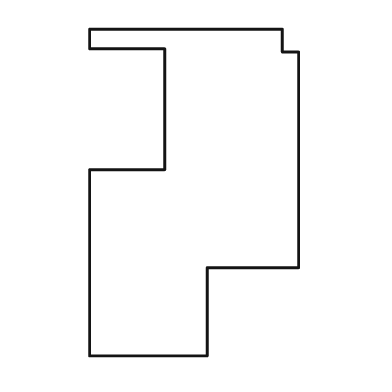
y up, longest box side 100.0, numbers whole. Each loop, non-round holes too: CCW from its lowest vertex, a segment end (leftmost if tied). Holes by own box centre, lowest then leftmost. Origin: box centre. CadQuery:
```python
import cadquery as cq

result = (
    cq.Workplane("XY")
    .moveTo(-32.0, -50.0)
    .lineTo(4.0, -50.0)
    .lineTo(4.0, -23.0)
    .lineTo(32.0, -23.0)
    .lineTo(32.0, 43.0)
    .lineTo(27.0, 43.0)
    .lineTo(27.0, 50.0)
    .lineTo(-32.0, 50.0)
    .lineTo(-32.0, 44.0)
    .lineTo(-9.0, 44.0)
    .lineTo(-9.0, 7.0)
    .lineTo(-32.0, 7.0)
    .close()
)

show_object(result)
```